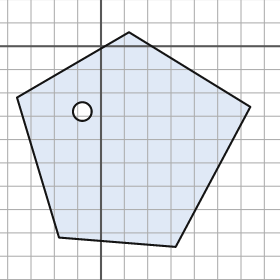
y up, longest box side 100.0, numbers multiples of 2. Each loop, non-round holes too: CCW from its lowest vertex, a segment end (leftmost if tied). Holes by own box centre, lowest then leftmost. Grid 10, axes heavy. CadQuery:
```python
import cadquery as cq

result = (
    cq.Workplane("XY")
    .moveTo(32.0, -86.0)
    .lineTo(64.0, -26.0)
    .lineTo(12.0, 6.0)
    .lineTo(-36.0, -22.0)
    .lineTo(-18.0, -82.0)
    .close()
    .moveTo(-8.0, -28.0)
    .circle(4.0)
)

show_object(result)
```